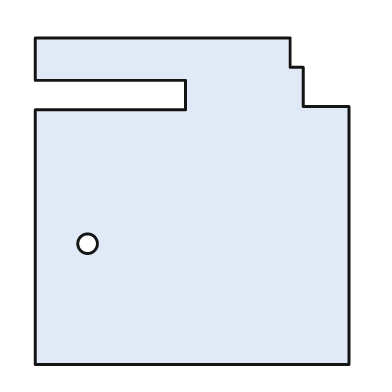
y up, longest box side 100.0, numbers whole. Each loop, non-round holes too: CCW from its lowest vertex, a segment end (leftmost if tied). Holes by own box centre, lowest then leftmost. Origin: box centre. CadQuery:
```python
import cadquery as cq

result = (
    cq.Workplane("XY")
    .moveTo(-48.0, -50.0)
    .lineTo(48.0, -50.0)
    .lineTo(48.0, 29.0)
    .lineTo(34.0, 29.0)
    .lineTo(34.0, 41.0)
    .lineTo(30.0, 41.0)
    .lineTo(30.0, 50.0)
    .lineTo(-48.0, 50.0)
    .lineTo(-48.0, 37.0)
    .lineTo(-2.0, 37.0)
    .lineTo(-2.0, 28.0)
    .lineTo(-48.0, 28.0)
    .close()
    .moveTo(-32.0, -13.0)
    .circle(3.0)
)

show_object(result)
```